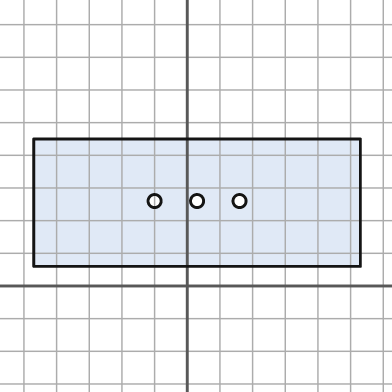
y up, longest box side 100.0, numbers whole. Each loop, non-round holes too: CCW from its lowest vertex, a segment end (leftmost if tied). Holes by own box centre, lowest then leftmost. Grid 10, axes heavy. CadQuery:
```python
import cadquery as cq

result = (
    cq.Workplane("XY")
    .moveTo(-47.0, 6.0)
    .lineTo(53.0, 6.0)
    .lineTo(53.0, 45.0)
    .lineTo(-47.0, 45.0)
    .close()
    .moveTo(-10.0, 26.0)
    .circle(2.0)
    .moveTo(3.0, 26.0)
    .circle(2.0)
    .moveTo(16.0, 26.0)
    .circle(2.0)
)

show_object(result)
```